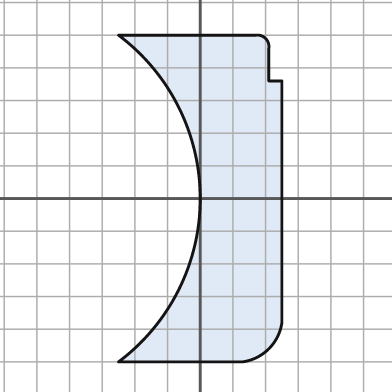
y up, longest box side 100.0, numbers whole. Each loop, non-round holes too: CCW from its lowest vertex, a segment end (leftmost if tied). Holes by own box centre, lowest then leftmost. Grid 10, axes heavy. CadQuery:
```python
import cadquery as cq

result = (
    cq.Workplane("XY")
    .moveTo(-25.0, -50.0)
    .lineTo(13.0, -50.0)
    .threePointArc((21.0, -46.0), (25.0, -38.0))
    .lineTo(25.0, 36.0)
    .lineTo(21.0, 36.0)
    .lineTo(21.0, 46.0)
    .threePointArc((20.0, 49.0), (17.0, 50.0))
    .lineTo(-25.0, 50.0)
    .threePointArc((0.0, 0.0), (-25.0, -50.0))
    .close()
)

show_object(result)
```